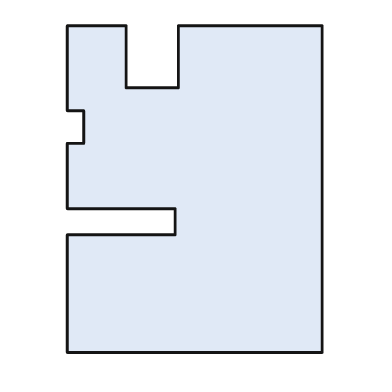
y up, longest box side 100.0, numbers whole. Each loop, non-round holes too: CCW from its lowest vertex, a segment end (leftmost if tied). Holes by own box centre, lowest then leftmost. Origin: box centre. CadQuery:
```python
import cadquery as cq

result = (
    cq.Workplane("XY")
    .moveTo(-39.0, -50.0)
    .lineTo(39.0, -50.0)
    .lineTo(39.0, 50.0)
    .lineTo(-5.0, 50.0)
    .lineTo(-5.0, 31.0)
    .lineTo(-21.0, 31.0)
    .lineTo(-21.0, 50.0)
    .lineTo(-39.0, 50.0)
    .lineTo(-39.0, 24.0)
    .lineTo(-34.0, 24.0)
    .lineTo(-34.0, 14.0)
    .lineTo(-39.0, 14.0)
    .lineTo(-39.0, -6.0)
    .lineTo(-6.0, -6.0)
    .lineTo(-6.0, -14.0)
    .lineTo(-39.0, -14.0)
    .close()
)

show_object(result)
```